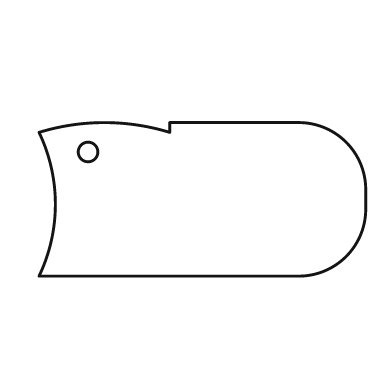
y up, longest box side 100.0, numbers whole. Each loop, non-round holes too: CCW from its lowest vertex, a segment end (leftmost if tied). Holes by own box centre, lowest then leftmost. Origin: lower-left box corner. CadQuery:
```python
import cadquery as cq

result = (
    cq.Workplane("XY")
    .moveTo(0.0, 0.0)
    .lineTo(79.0, 0.0)
    .threePointArc((94.0, 6.0), (100.0, 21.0))
    .lineTo(100.0, 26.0)
    .threePointArc((94.0, 41.0), (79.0, 47.0))
    .lineTo(40.0, 47.0)
    .lineTo(40.0, 44.0)
    .threePointArc((20.0, 47.0), (0.0, 44.0))
    .threePointArc((5.0, 22.0), (0.0, 0.0))
    .close()
    .moveTo(15.0, 38.0)
    .circle(3.0)
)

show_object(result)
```